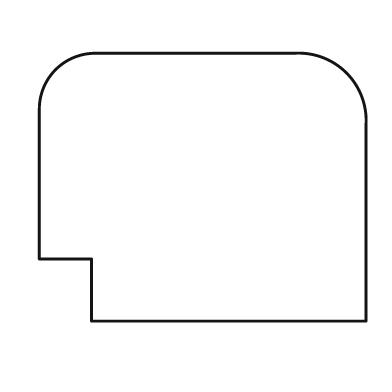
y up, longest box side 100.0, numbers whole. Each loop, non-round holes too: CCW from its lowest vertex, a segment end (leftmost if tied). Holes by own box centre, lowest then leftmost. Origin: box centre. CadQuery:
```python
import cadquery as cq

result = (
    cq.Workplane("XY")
    .moveTo(-34.0, -41.0)
    .lineTo(50.0, -41.0)
    .lineTo(50.0, 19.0)
    .threePointArc((44.0, 35.0), (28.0, 41.0))
    .lineTo(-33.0, 41.0)
    .threePointArc((-45.0, 36.0), (-50.0, 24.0))
    .lineTo(-50.0, -22.0)
    .lineTo(-34.0, -22.0)
    .close()
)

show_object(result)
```